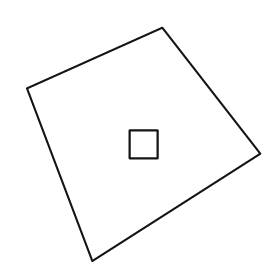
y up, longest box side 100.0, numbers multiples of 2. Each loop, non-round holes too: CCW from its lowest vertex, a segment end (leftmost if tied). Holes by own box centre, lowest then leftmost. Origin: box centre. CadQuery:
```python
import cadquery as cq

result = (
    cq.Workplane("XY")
    .moveTo(-22.0, -50.0)
    .lineTo(50.0, -4.0)
    .lineTo(8.0, 50.0)
    .lineTo(-50.0, 24.0)
    .close()
    .moveTo(-6.0, -6.0)
    .lineTo(6.0, -6.0)
    .lineTo(6.0, 6.0)
    .lineTo(-6.0, 6.0)
    .close()
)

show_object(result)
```